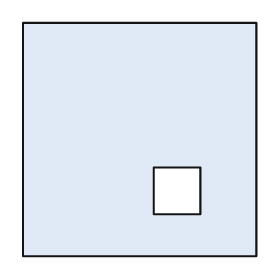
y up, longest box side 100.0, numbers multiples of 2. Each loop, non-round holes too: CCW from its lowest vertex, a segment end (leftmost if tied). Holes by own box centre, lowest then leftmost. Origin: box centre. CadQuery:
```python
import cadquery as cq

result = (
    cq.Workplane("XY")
    .moveTo(-50.0, -50.0)
    .lineTo(50.0, -50.0)
    .lineTo(50.0, 50.0)
    .lineTo(-50.0, 50.0)
    .close()
    .moveTo(6.0, -32.0)
    .lineTo(26.0, -32.0)
    .lineTo(26.0, -12.0)
    .lineTo(6.0, -12.0)
    .close()
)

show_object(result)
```